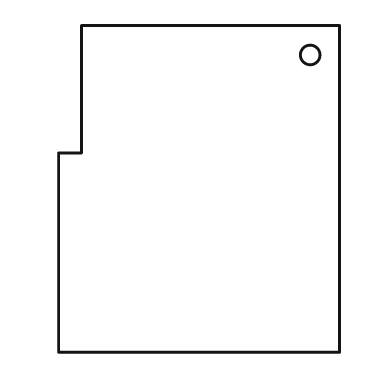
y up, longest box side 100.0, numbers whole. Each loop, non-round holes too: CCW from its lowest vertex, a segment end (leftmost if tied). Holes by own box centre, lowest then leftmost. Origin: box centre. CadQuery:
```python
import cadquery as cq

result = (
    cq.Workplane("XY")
    .moveTo(-43.0, -50.0)
    .lineTo(43.0, -50.0)
    .lineTo(43.0, 50.0)
    .lineTo(-36.0, 50.0)
    .lineTo(-36.0, 11.0)
    .lineTo(-43.0, 11.0)
    .close()
    .moveTo(34.0, 41.0)
    .circle(3.0)
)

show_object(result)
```